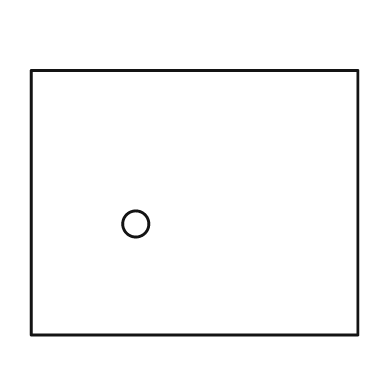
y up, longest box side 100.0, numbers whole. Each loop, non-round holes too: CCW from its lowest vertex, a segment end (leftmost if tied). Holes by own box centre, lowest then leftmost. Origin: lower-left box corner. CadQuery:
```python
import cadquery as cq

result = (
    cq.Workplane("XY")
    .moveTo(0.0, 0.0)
    .lineTo(100.0, 0.0)
    .lineTo(100.0, 81.0)
    .lineTo(0.0, 81.0)
    .close()
    .moveTo(32.0, 34.0)
    .circle(4.0)
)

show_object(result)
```